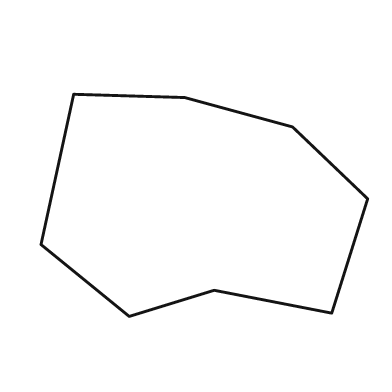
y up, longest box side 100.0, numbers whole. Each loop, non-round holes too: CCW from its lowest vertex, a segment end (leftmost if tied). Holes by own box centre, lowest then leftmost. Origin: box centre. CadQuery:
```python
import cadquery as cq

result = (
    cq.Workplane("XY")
    .moveTo(-23.0, -34.0)
    .lineTo(3.0, -26.0)
    .lineTo(39.0, -33.0)
    .lineTo(50.0, 2.0)
    .lineTo(27.0, 24.0)
    .lineTo(-6.0, 33.0)
    .lineTo(-40.0, 34.0)
    .lineTo(-50.0, -12.0)
    .close()
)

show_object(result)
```